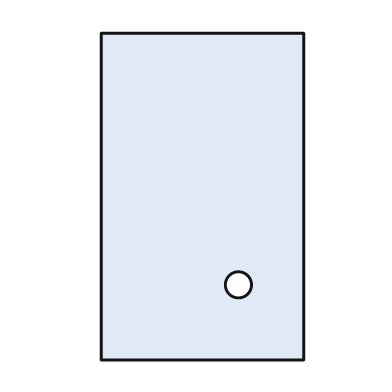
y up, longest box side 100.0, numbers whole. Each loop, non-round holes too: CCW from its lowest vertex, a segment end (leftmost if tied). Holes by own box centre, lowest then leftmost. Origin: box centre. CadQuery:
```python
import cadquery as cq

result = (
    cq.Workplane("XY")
    .moveTo(-31.0, -50.0)
    .lineTo(31.0, -50.0)
    .lineTo(31.0, 50.0)
    .lineTo(-31.0, 50.0)
    .close()
    .moveTo(11.0, -27.0)
    .circle(4.0)
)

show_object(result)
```